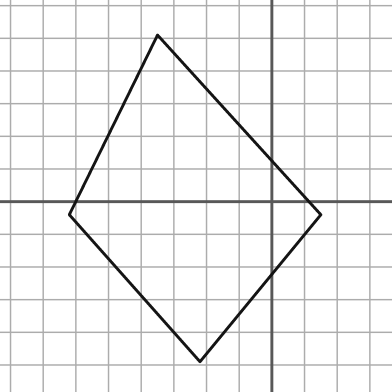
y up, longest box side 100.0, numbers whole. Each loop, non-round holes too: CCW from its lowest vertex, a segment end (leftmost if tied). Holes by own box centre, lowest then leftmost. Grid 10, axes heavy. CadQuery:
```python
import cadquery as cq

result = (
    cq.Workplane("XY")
    .moveTo(-22.0, -49.0)
    .lineTo(15.0, -4.0)
    .lineTo(-35.0, 51.0)
    .lineTo(-62.0, -4.0)
    .close()
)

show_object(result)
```